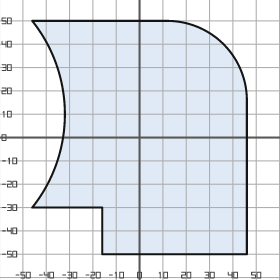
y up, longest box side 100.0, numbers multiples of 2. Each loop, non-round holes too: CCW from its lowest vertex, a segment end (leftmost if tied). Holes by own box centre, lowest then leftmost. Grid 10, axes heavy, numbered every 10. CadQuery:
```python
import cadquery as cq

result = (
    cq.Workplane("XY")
    .moveTo(-16.0, -50.0)
    .lineTo(46.0, -50.0)
    .lineTo(46.0, 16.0)
    .threePointArc((36.0, 40.0), (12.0, 50.0))
    .lineTo(-46.0, 50.0)
    .threePointArc((-32.0, 10.0), (-46.0, -30.0))
    .lineTo(-16.0, -30.0)
    .close()
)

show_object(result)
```